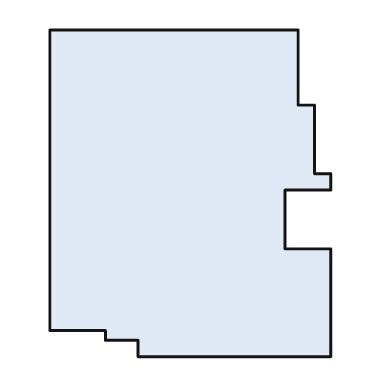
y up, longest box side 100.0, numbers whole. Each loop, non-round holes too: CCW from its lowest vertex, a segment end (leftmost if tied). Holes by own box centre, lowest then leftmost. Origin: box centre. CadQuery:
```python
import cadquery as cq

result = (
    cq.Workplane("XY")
    .moveTo(-16.0, -50.0)
    .lineTo(43.0, -50.0)
    .lineTo(43.0, -17.0)
    .lineTo(29.0, -17.0)
    .lineTo(29.0, 1.0)
    .lineTo(43.0, 1.0)
    .lineTo(43.0, 6.0)
    .lineTo(38.0, 6.0)
    .lineTo(38.0, 27.0)
    .lineTo(33.0, 27.0)
    .lineTo(33.0, 50.0)
    .lineTo(-43.0, 50.0)
    .lineTo(-43.0, -42.0)
    .lineTo(-26.0, -42.0)
    .lineTo(-26.0, -45.0)
    .lineTo(-16.0, -45.0)
    .close()
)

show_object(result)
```